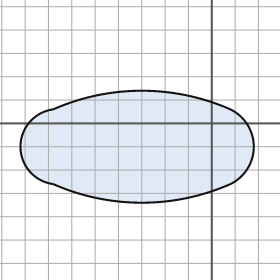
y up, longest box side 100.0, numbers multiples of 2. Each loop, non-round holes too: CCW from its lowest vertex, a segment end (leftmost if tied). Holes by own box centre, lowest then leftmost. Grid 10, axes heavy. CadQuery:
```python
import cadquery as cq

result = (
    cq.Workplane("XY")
    .moveTo(-68.0, -26.0)
    .threePointArc((-30.0, -34.0), (8.0, -26.0))
    .threePointArc((18.0, -10.0), (8.0, 6.0))
    .threePointArc((-30.0, 14.0), (-68.0, 6.0))
    .threePointArc((-82.0, -10.0), (-68.0, -26.0))
    .close()
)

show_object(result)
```